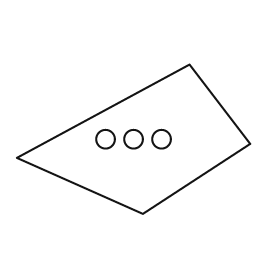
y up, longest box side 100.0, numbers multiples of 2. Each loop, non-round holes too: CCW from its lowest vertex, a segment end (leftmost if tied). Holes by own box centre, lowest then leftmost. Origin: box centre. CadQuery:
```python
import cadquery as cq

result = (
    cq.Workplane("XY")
    .moveTo(4.0, -32.0)
    .lineTo(50.0, -2.0)
    .lineTo(24.0, 32.0)
    .lineTo(-50.0, -8.0)
    .close()
    .moveTo(-12.0, 0.0)
    .circle(4.0)
    .moveTo(0.0, 0.0)
    .circle(4.0)
    .moveTo(12.0, 0.0)
    .circle(4.0)
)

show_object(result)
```